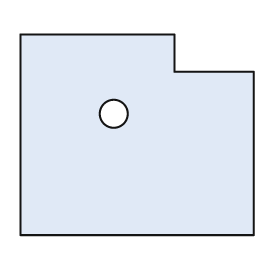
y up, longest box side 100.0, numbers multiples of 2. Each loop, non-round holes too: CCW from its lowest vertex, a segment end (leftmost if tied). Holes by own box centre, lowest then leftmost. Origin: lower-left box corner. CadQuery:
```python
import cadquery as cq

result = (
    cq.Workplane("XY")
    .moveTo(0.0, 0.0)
    .lineTo(100.0, 0.0)
    .lineTo(100.0, 70.0)
    .lineTo(66.0, 70.0)
    .lineTo(66.0, 86.0)
    .lineTo(0.0, 86.0)
    .close()
    .moveTo(40.0, 52.0)
    .circle(6.0)
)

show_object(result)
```